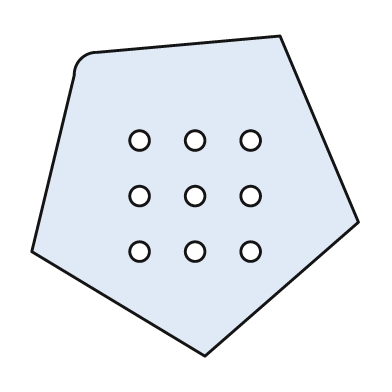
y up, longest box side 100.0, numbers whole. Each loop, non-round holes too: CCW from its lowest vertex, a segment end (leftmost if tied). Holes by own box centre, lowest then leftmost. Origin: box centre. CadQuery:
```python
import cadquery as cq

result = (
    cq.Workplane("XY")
    .moveTo(3.0, -49.0)
    .lineTo(50.0, -8.0)
    .lineTo(26.0, 49.0)
    .lineTo(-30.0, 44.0)
    .threePointArc((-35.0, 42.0), (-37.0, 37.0))
    .lineTo(-50.0, -17.0)
    .close()
    .moveTo(-17.0, -17.0)
    .circle(3.0)
    .moveTo(0.0, -17.0)
    .circle(3.0)
    .moveTo(17.0, -17.0)
    .circle(3.0)
    .moveTo(-17.0, 0.0)
    .circle(3.0)
    .moveTo(0.0, 0.0)
    .circle(3.0)
    .moveTo(17.0, 0.0)
    .circle(3.0)
    .moveTo(-17.0, 17.0)
    .circle(3.0)
    .moveTo(0.0, 17.0)
    .circle(3.0)
    .moveTo(17.0, 17.0)
    .circle(3.0)
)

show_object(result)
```